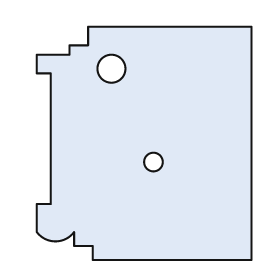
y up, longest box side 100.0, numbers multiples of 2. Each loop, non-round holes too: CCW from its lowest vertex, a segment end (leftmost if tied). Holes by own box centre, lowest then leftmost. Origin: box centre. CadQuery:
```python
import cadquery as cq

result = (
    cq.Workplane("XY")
    .moveTo(-22.0, -50.0)
    .lineTo(46.0, -50.0)
    .lineTo(46.0, 50.0)
    .lineTo(-24.0, 50.0)
    .lineTo(-24.0, 42.0)
    .lineTo(-32.0, 42.0)
    .lineTo(-32.0, 38.0)
    .lineTo(-46.0, 38.0)
    .lineTo(-46.0, 30.0)
    .lineTo(-40.0, 30.0)
    .lineTo(-40.0, -26.0)
    .lineTo(-46.0, -26.0)
    .lineTo(-46.0, -38.0)
    .threePointArc((-38.0, -42.0), (-30.0, -38.0))
    .lineTo(-30.0, -44.0)
    .lineTo(-22.0, -44.0)
    .close()
    .moveTo(4.0, -8.0)
    .circle(4.0)
    .moveTo(-14.0, 32.0)
    .circle(6.0)
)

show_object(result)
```